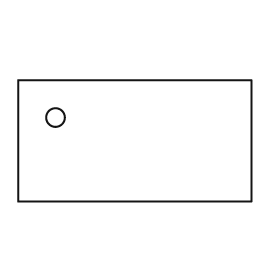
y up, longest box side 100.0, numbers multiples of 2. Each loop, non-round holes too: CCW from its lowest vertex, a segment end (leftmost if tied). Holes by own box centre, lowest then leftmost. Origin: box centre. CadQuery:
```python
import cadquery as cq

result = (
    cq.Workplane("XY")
    .moveTo(-50.0, -26.0)
    .lineTo(50.0, -26.0)
    .lineTo(50.0, 26.0)
    .lineTo(-50.0, 26.0)
    .close()
    .moveTo(-34.0, 10.0)
    .circle(4.0)
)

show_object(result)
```